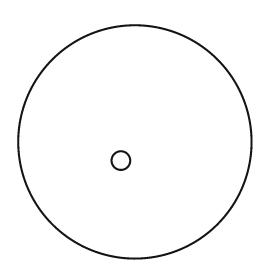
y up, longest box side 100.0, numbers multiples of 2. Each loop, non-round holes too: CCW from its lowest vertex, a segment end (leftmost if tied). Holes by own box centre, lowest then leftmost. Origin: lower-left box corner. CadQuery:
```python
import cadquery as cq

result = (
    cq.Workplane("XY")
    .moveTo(50.0, 50.0)
    .circle(50.0)
    .moveTo(44.0, 42.0)
    .circle(4.0)
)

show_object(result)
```